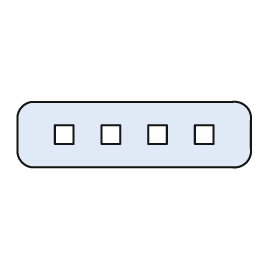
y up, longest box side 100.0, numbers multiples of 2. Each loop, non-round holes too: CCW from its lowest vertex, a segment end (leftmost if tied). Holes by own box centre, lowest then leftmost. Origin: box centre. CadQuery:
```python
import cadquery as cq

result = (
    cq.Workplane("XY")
    .moveTo(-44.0, -14.0)
    .lineTo(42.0, -14.0)
    .threePointArc((48.0, -12.0), (50.0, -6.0))
    .lineTo(50.0, 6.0)
    .threePointArc((48.0, 12.0), (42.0, 14.0))
    .lineTo(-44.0, 14.0)
    .threePointArc((-48.0, 12.0), (-50.0, 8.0))
    .lineTo(-50.0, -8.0)
    .threePointArc((-48.0, -12.0), (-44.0, -14.0))
    .close()
    .moveTo(-34.0, -4.0)
    .lineTo(-26.0, -4.0)
    .lineTo(-26.0, 4.0)
    .lineTo(-34.0, 4.0)
    .close()
    .moveTo(-14.0, -4.0)
    .lineTo(-6.0, -4.0)
    .lineTo(-6.0, 4.0)
    .lineTo(-14.0, 4.0)
    .close()
    .moveTo(6.0, -4.0)
    .lineTo(14.0, -4.0)
    .lineTo(14.0, 4.0)
    .lineTo(6.0, 4.0)
    .close()
    .moveTo(26.0, -4.0)
    .lineTo(34.0, -4.0)
    .lineTo(34.0, 4.0)
    .lineTo(26.0, 4.0)
    .close()
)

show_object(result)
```